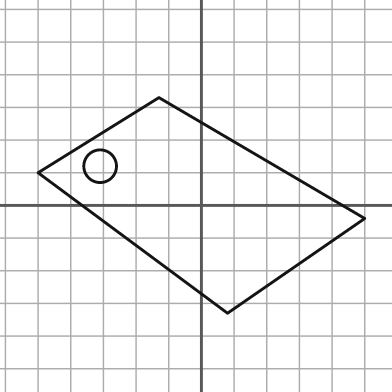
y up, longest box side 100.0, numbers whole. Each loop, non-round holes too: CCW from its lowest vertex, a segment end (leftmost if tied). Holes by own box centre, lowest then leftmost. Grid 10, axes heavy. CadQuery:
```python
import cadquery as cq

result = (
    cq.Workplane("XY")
    .moveTo(8.0, -33.0)
    .lineTo(50.0, -4.0)
    .lineTo(-13.0, 33.0)
    .lineTo(-50.0, 10.0)
    .close()
    .moveTo(-31.0, 12.0)
    .circle(5.0)
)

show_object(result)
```